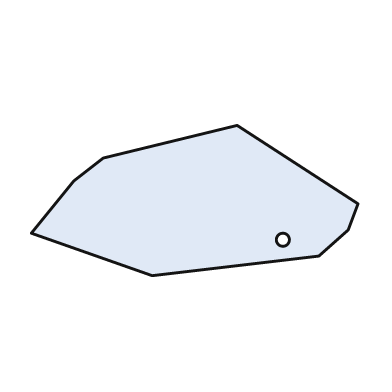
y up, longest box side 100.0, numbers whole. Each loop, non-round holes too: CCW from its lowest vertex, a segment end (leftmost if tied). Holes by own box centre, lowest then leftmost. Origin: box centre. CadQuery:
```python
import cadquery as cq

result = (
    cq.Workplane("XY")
    .moveTo(-13.0, -23.0)
    .lineTo(38.0, -17.0)
    .lineTo(47.0, -9.0)
    .lineTo(50.0, -1.0)
    .lineTo(13.0, 23.0)
    .lineTo(-28.0, 13.0)
    .lineTo(-37.0, 6.0)
    .lineTo(-50.0, -10.0)
    .close()
    .moveTo(27.0, -12.0)
    .circle(2.0)
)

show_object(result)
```